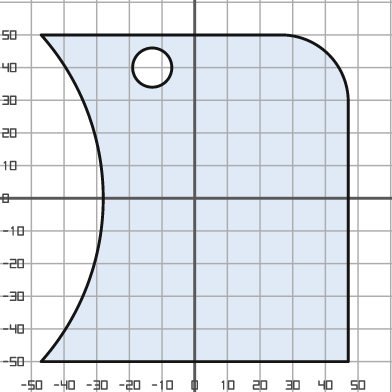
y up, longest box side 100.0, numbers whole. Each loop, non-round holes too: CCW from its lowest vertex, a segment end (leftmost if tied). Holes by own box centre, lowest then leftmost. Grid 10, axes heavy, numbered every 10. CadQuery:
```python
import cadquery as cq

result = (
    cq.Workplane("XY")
    .moveTo(-47.0, -50.0)
    .lineTo(47.0, -50.0)
    .lineTo(47.0, 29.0)
    .threePointArc((41.0, 44.0), (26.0, 50.0))
    .lineTo(-47.0, 50.0)
    .threePointArc((-28.0, 0.0), (-47.0, -50.0))
    .close()
    .moveTo(-13.0, 40.0)
    .circle(6.0)
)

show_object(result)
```